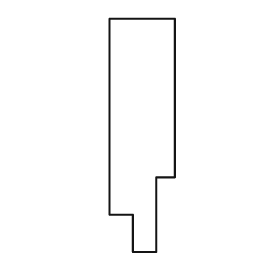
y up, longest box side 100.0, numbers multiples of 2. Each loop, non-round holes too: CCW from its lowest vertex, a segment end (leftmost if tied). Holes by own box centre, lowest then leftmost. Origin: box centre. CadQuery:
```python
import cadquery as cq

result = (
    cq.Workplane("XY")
    .moveTo(-4.0, -50.0)
    .lineTo(6.0, -50.0)
    .lineTo(6.0, -18.0)
    .lineTo(14.0, -18.0)
    .lineTo(14.0, 50.0)
    .lineTo(-14.0, 50.0)
    .lineTo(-14.0, -34.0)
    .lineTo(-4.0, -34.0)
    .close()
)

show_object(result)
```